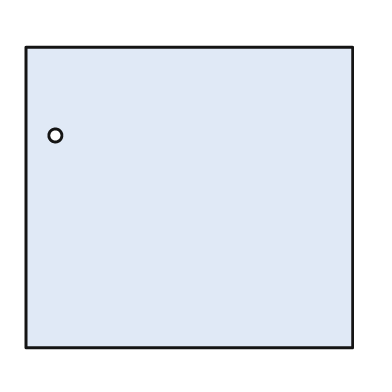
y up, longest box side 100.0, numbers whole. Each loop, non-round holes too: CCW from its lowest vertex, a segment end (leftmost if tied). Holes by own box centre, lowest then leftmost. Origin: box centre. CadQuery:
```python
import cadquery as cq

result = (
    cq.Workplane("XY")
    .moveTo(-50.0, -46.0)
    .lineTo(50.0, -46.0)
    .lineTo(50.0, 46.0)
    .lineTo(-50.0, 46.0)
    .close()
    .moveTo(-41.0, 19.0)
    .circle(2.0)
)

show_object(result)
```